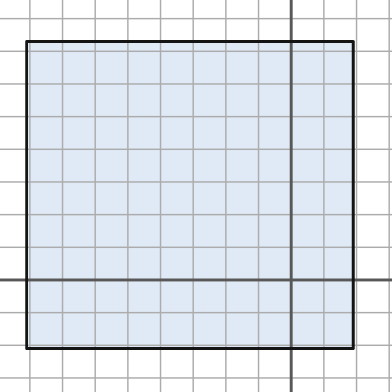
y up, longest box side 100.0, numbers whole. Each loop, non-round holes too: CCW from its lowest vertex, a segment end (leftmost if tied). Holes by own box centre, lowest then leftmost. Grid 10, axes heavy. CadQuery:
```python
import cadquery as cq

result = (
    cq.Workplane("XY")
    .moveTo(-81.0, -21.0)
    .lineTo(19.0, -21.0)
    .lineTo(19.0, 73.0)
    .lineTo(-81.0, 73.0)
    .close()
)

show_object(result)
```